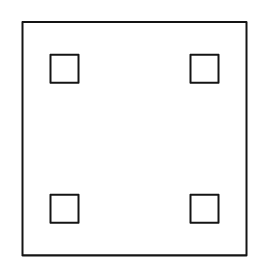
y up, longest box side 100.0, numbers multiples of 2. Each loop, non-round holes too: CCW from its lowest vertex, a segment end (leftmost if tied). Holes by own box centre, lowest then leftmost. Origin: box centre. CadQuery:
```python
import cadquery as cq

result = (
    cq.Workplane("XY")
    .moveTo(-48.0, -50.0)
    .lineTo(48.0, -50.0)
    .lineTo(48.0, 50.0)
    .lineTo(-48.0, 50.0)
    .close()
    .moveTo(-36.0, -36.0)
    .lineTo(-24.0, -36.0)
    .lineTo(-24.0, -24.0)
    .lineTo(-36.0, -24.0)
    .close()
    .moveTo(24.0, -36.0)
    .lineTo(36.0, -36.0)
    .lineTo(36.0, -24.0)
    .lineTo(24.0, -24.0)
    .close()
    .moveTo(-36.0, 24.0)
    .lineTo(-24.0, 24.0)
    .lineTo(-24.0, 36.0)
    .lineTo(-36.0, 36.0)
    .close()
    .moveTo(24.0, 24.0)
    .lineTo(36.0, 24.0)
    .lineTo(36.0, 36.0)
    .lineTo(24.0, 36.0)
    .close()
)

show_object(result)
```